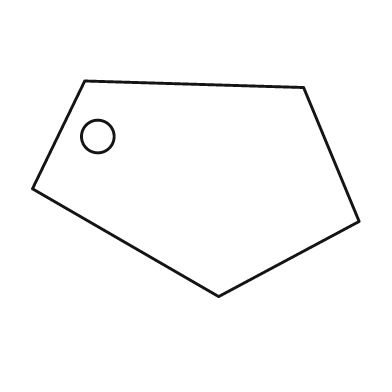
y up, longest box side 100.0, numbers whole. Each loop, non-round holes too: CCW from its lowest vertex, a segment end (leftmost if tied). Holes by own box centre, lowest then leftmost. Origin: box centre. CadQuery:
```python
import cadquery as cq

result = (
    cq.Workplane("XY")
    .moveTo(7.0, -33.0)
    .lineTo(50.0, -10.0)
    .lineTo(33.0, 31.0)
    .lineTo(-34.0, 33.0)
    .lineTo(-50.0, 0.0)
    .close()
    .moveTo(-30.0, 16.0)
    .circle(5.0)
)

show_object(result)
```